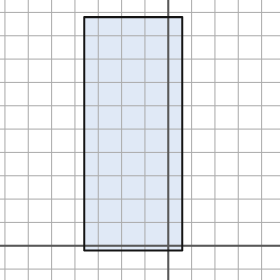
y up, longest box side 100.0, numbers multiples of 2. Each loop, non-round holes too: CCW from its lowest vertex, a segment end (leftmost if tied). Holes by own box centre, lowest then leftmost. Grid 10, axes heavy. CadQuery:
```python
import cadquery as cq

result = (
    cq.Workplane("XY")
    .moveTo(-36.0, -2.0)
    .lineTo(6.0, -2.0)
    .lineTo(6.0, 98.0)
    .lineTo(-36.0, 98.0)
    .close()
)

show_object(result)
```